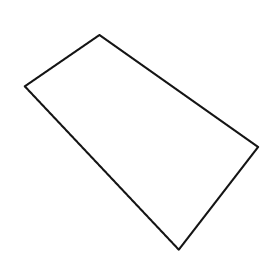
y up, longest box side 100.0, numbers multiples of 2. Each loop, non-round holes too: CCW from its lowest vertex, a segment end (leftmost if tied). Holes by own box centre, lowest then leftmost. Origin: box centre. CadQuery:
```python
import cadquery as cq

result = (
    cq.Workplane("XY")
    .moveTo(16.0, -46.0)
    .lineTo(50.0, -2.0)
    .lineTo(-18.0, 46.0)
    .lineTo(-50.0, 24.0)
    .close()
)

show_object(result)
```